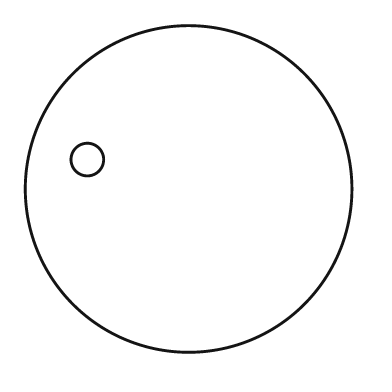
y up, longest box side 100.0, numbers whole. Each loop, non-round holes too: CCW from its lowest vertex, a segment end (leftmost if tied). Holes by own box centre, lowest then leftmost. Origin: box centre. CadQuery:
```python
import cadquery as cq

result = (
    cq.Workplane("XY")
    .moveTo(0.0, 0.0)
    .circle(50.0)
    .moveTo(-31.0, 9.0)
    .circle(5.0)
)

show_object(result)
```